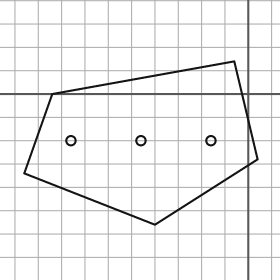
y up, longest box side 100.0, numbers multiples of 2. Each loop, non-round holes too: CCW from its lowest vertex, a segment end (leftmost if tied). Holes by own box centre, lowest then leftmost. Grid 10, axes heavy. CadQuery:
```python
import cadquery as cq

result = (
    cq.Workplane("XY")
    .moveTo(-40.0, -56.0)
    .lineTo(4.0, -28.0)
    .lineTo(-6.0, 14.0)
    .lineTo(-84.0, 0.0)
    .lineTo(-96.0, -34.0)
    .close()
    .moveTo(-76.0, -20.0)
    .circle(2.0)
    .moveTo(-46.0, -20.0)
    .circle(2.0)
    .moveTo(-16.0, -20.0)
    .circle(2.0)
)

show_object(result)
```